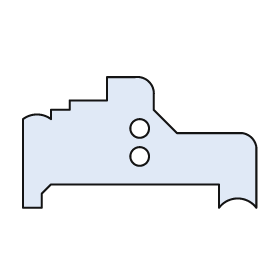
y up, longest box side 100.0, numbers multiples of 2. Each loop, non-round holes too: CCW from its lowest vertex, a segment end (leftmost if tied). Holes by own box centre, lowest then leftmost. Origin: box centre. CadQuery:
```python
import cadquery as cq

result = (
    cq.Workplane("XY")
    .moveTo(-50.0, -28.0)
    .lineTo(-42.0, -28.0)
    .lineTo(-42.0, -22.0)
    .lineTo(-38.0, -18.0)
    .lineTo(34.0, -18.0)
    .lineTo(34.0, -28.0)
    .threePointArc((42.0, -24.0), (50.0, -28.0))
    .lineTo(50.0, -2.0)
    .threePointArc((48.0, 2.0), (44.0, 4.0))
    .lineTo(16.0, 4.0)
    .lineTo(6.0, 14.0)
    .lineTo(6.0, 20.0)
    .threePointArc((4.0, 26.0), (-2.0, 28.0))
    .lineTo(-14.0, 28.0)
    .lineTo(-14.0, 18.0)
    .lineTo(-30.0, 18.0)
    .lineTo(-30.0, 14.0)
    .lineTo(-38.0, 14.0)
    .lineTo(-38.0, 10.0)
    .threePointArc((-44.0, 12.0), (-50.0, 10.0))
    .close()
    .moveTo(0.0, -6.0)
    .circle(4.0)
    .moveTo(0.0, 6.0)
    .circle(4.0)
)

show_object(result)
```